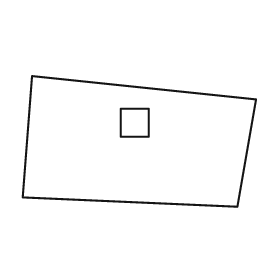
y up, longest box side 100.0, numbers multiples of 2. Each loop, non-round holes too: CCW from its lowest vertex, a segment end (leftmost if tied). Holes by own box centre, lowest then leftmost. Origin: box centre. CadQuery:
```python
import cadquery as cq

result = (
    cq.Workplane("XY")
    .moveTo(42.0, -28.0)
    .lineTo(50.0, 18.0)
    .lineTo(-46.0, 28.0)
    .lineTo(-50.0, -24.0)
    .close()
    .moveTo(-8.0, 2.0)
    .lineTo(4.0, 2.0)
    .lineTo(4.0, 14.0)
    .lineTo(-8.0, 14.0)
    .close()
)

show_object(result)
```